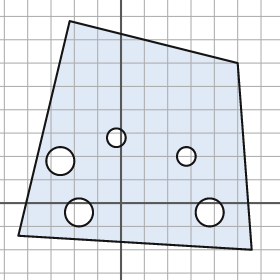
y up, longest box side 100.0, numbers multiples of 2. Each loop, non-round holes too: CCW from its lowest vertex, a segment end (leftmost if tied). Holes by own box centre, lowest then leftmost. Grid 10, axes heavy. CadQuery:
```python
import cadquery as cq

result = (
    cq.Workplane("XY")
    .moveTo(56.0, -20.0)
    .lineTo(50.0, 60.0)
    .lineTo(-22.0, 78.0)
    .lineTo(-44.0, -14.0)
    .close()
    .moveTo(-18.0, -4.0)
    .circle(6.0)
    .moveTo(38.0, -4.0)
    .circle(6.0)
    .moveTo(-26.0, 18.0)
    .circle(6.0)
    .moveTo(28.0, 20.0)
    .circle(4.0)
    .moveTo(-2.0, 28.0)
    .circle(4.0)
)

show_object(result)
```